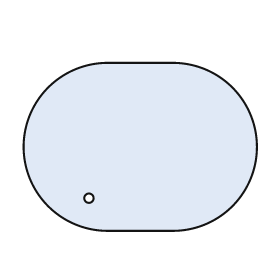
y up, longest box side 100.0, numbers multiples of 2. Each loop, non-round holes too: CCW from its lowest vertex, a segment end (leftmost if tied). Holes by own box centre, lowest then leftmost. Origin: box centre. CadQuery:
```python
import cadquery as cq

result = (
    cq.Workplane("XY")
    .moveTo(-14.0, -36.0)
    .lineTo(14.0, -36.0)
    .threePointArc((50.0, 0.0), (14.0, 36.0))
    .lineTo(-14.0, 36.0)
    .threePointArc((-50.0, 0.0), (-14.0, -36.0))
    .close()
    .moveTo(-22.0, -22.0)
    .circle(2.0)
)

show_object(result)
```